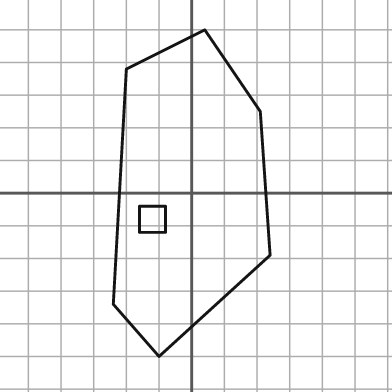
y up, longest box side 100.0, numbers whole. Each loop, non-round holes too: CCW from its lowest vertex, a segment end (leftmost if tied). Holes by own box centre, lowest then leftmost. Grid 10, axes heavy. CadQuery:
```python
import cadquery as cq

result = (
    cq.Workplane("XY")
    .moveTo(-10.0, -50.0)
    .lineTo(24.0, -19.0)
    .lineTo(21.0, 25.0)
    .lineTo(4.0, 50.0)
    .lineTo(-20.0, 38.0)
    .lineTo(-24.0, -34.0)
    .close()
    .moveTo(-16.0, -12.0)
    .lineTo(-8.0, -12.0)
    .lineTo(-8.0, -4.0)
    .lineTo(-16.0, -4.0)
    .close()
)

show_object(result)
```